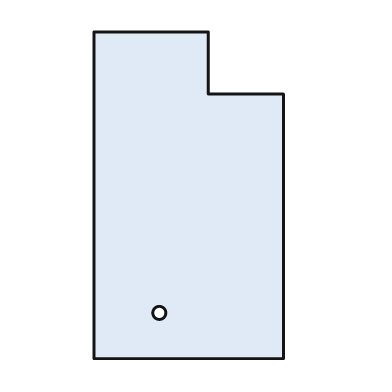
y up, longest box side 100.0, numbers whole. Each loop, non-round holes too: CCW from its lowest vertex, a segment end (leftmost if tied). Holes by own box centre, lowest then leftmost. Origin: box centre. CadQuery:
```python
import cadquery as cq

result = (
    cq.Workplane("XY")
    .moveTo(-29.0, -50.0)
    .lineTo(29.0, -50.0)
    .lineTo(29.0, 31.0)
    .lineTo(6.0, 31.0)
    .lineTo(6.0, 50.0)
    .lineTo(-29.0, 50.0)
    .close()
    .moveTo(-9.0, -36.0)
    .circle(2.0)
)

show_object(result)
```